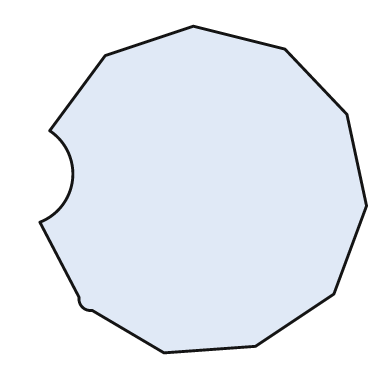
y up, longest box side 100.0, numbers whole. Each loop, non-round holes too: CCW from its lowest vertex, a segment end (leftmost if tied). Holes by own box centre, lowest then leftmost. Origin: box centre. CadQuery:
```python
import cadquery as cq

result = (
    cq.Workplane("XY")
    .moveTo(-12.0, -50.0)
    .lineTo(16.0, -48.0)
    .lineTo(40.0, -32.0)
    .lineTo(50.0, -5.0)
    .lineTo(44.0, 23.0)
    .lineTo(25.0, 43.0)
    .lineTo(-3.0, 50.0)
    .lineTo(-30.0, 41.0)
    .lineTo(-47.0, 18.0)
    .threePointArc((-40.0, 3.0), (-50.0, -10.0))
    .lineTo(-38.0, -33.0)
    .threePointArc((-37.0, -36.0), (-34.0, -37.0))
    .close()
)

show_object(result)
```